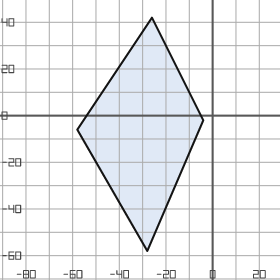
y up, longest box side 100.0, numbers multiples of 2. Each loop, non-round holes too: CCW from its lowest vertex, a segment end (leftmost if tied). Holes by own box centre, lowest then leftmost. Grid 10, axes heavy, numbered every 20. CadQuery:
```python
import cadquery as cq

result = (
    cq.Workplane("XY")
    .moveTo(-28.0, -58.0)
    .lineTo(-4.0, -2.0)
    .lineTo(-26.0, 42.0)
    .lineTo(-58.0, -6.0)
    .close()
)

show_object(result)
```